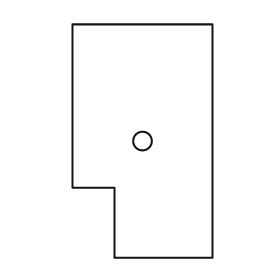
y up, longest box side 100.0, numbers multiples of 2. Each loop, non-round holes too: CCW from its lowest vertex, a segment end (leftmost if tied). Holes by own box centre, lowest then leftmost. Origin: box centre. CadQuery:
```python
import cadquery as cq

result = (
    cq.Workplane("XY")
    .moveTo(-12.0, -50.0)
    .lineTo(30.0, -50.0)
    .lineTo(30.0, 50.0)
    .lineTo(-30.0, 50.0)
    .lineTo(-30.0, -20.0)
    .lineTo(-12.0, -20.0)
    .close()
    .moveTo(0.0, 0.0)
    .circle(4.0)
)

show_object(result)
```